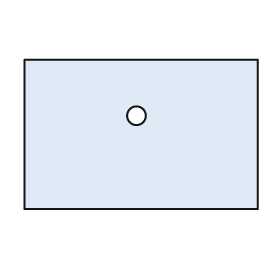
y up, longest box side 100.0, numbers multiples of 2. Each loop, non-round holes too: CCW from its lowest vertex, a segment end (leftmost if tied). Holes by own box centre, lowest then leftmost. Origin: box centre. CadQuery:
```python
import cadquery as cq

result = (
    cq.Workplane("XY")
    .moveTo(-50.0, -32.0)
    .lineTo(50.0, -32.0)
    .lineTo(50.0, 32.0)
    .lineTo(-50.0, 32.0)
    .close()
    .moveTo(-2.0, 8.0)
    .circle(4.0)
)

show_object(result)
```